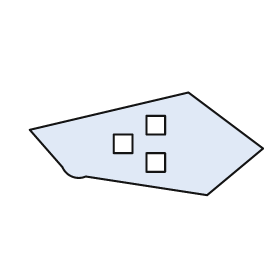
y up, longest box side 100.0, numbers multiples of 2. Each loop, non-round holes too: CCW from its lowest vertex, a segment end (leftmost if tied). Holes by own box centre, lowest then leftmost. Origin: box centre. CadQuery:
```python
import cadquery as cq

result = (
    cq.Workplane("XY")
    .moveTo(26.0, -22.0)
    .lineTo(50.0, -2.0)
    .lineTo(18.0, 22.0)
    .lineTo(-50.0, 6.0)
    .lineTo(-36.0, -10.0)
    .threePointArc((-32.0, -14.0), (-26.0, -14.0))
    .close()
    .moveTo(0.0, -12.0)
    .lineTo(8.0, -12.0)
    .lineTo(8.0, -4.0)
    .lineTo(0.0, -4.0)
    .close()
    .moveTo(-14.0, -4.0)
    .lineTo(-6.0, -4.0)
    .lineTo(-6.0, 4.0)
    .lineTo(-14.0, 4.0)
    .close()
    .moveTo(0.0, 4.0)
    .lineTo(8.0, 4.0)
    .lineTo(8.0, 12.0)
    .lineTo(0.0, 12.0)
    .close()
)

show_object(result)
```